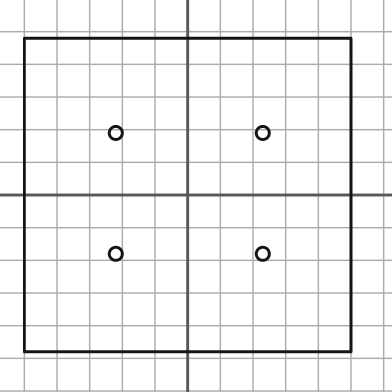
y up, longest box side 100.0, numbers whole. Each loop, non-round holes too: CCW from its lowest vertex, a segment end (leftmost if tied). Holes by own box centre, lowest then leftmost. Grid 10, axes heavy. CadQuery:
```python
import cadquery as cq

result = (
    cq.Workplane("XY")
    .moveTo(-50.0, -48.0)
    .lineTo(50.0, -48.0)
    .lineTo(50.0, 48.0)
    .lineTo(-50.0, 48.0)
    .close()
    .moveTo(-22.0, -18.0)
    .circle(2.0)
    .moveTo(23.0, -18.0)
    .circle(2.0)
    .moveTo(-22.0, 19.0)
    .circle(2.0)
    .moveTo(23.0, 19.0)
    .circle(2.0)
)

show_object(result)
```